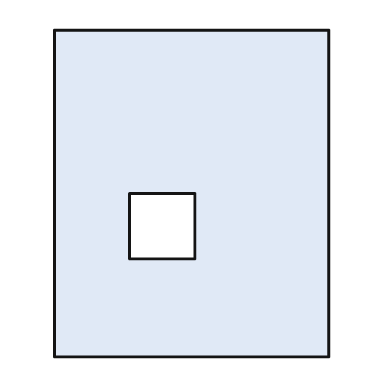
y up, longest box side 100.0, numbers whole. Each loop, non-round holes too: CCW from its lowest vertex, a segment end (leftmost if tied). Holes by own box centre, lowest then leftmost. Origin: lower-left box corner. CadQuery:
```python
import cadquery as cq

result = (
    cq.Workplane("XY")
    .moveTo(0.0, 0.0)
    .lineTo(84.0, 0.0)
    .lineTo(84.0, 100.0)
    .lineTo(0.0, 100.0)
    .close()
    .moveTo(23.0, 30.0)
    .lineTo(43.0, 30.0)
    .lineTo(43.0, 50.0)
    .lineTo(23.0, 50.0)
    .close()
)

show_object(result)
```